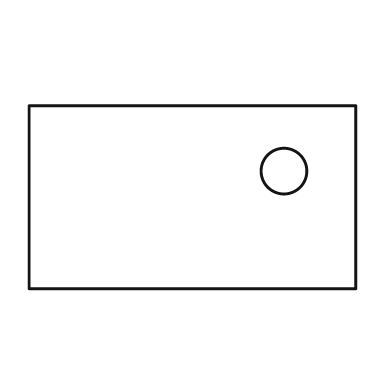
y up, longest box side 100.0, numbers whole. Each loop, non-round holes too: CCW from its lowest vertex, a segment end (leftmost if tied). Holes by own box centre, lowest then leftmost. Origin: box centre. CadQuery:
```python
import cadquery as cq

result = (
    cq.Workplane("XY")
    .moveTo(-50.0, -28.0)
    .lineTo(50.0, -28.0)
    .lineTo(50.0, 28.0)
    .lineTo(-50.0, 28.0)
    .close()
    .moveTo(28.0, 8.0)
    .circle(7.0)
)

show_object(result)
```